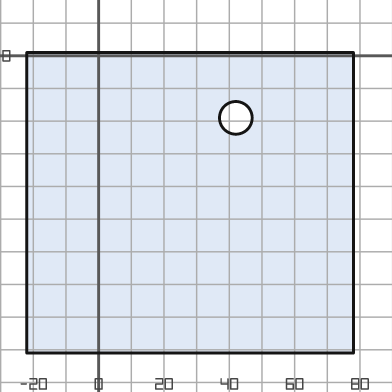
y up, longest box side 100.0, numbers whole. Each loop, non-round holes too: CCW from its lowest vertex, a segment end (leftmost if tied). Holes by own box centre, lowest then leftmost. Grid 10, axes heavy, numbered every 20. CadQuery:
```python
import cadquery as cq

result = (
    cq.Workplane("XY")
    .moveTo(-22.0, -91.0)
    .lineTo(78.0, -91.0)
    .lineTo(78.0, 1.0)
    .lineTo(-22.0, 1.0)
    .close()
    .moveTo(42.0, -19.0)
    .circle(5.0)
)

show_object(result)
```